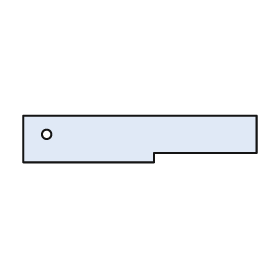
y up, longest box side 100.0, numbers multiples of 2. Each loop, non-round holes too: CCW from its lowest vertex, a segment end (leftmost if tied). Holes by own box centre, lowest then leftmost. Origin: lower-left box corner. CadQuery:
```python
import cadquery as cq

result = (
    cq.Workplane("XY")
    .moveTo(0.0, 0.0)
    .lineTo(56.0, 0.0)
    .lineTo(56.0, 4.0)
    .lineTo(100.0, 4.0)
    .lineTo(100.0, 20.0)
    .lineTo(0.0, 20.0)
    .close()
    .moveTo(10.0, 12.0)
    .circle(2.0)
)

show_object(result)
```